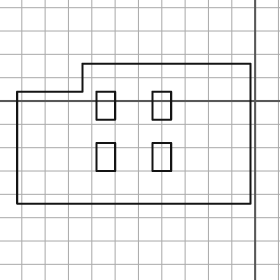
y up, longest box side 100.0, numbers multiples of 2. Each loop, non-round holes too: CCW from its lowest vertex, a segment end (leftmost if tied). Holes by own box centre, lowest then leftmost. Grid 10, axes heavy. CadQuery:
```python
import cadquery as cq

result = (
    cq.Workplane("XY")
    .moveTo(-102.0, -44.0)
    .lineTo(-2.0, -44.0)
    .lineTo(-2.0, 16.0)
    .lineTo(-74.0, 16.0)
    .lineTo(-74.0, 4.0)
    .lineTo(-102.0, 4.0)
    .close()
    .moveTo(-68.0, -30.0)
    .lineTo(-60.0, -30.0)
    .lineTo(-60.0, -18.0)
    .lineTo(-68.0, -18.0)
    .close()
    .moveTo(-44.0, -30.0)
    .lineTo(-36.0, -30.0)
    .lineTo(-36.0, -18.0)
    .lineTo(-44.0, -18.0)
    .close()
    .moveTo(-68.0, -8.0)
    .lineTo(-60.0, -8.0)
    .lineTo(-60.0, 4.0)
    .lineTo(-68.0, 4.0)
    .close()
    .moveTo(-44.0, -8.0)
    .lineTo(-36.0, -8.0)
    .lineTo(-36.0, 4.0)
    .lineTo(-44.0, 4.0)
    .close()
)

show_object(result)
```